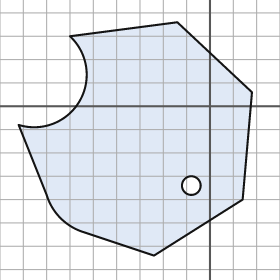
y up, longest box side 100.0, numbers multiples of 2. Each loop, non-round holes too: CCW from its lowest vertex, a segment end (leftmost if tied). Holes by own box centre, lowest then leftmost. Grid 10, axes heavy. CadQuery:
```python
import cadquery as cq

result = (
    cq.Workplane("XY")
    .moveTo(-24.0, -64.0)
    .lineTo(14.0, -40.0)
    .lineTo(18.0, 6.0)
    .lineTo(-14.0, 36.0)
    .lineTo(-60.0, 30.0)
    .threePointArc((-56.0, 2.0), (-82.0, -8.0))
    .lineTo(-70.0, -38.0)
    .threePointArc((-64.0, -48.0), (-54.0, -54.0))
    .close()
    .moveTo(-8.0, -34.0)
    .circle(4.0)
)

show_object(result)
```